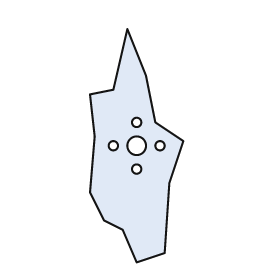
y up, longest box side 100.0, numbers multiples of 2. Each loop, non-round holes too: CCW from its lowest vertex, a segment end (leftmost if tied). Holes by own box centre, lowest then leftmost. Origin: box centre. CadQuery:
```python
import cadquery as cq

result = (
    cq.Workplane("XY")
    .moveTo(0.0, -50.0)
    .lineTo(12.0, -46.0)
    .lineTo(14.0, -16.0)
    .lineTo(20.0, 2.0)
    .lineTo(8.0, 10.0)
    .lineTo(4.0, 30.0)
    .lineTo(-4.0, 50.0)
    .lineTo(-10.0, 24.0)
    .lineTo(-20.0, 22.0)
    .lineTo(-18.0, 4.0)
    .lineTo(-20.0, -20.0)
    .lineTo(-14.0, -32.0)
    .lineTo(-6.0, -36.0)
    .close()
    .moveTo(0.0, -10.0)
    .circle(2.0)
    .moveTo(-10.0, 0.0)
    .circle(2.0)
    .moveTo(0.0, 0.0)
    .circle(4.0)
    .moveTo(10.0, 0.0)
    .circle(2.0)
    .moveTo(0.0, 10.0)
    .circle(2.0)
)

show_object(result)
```